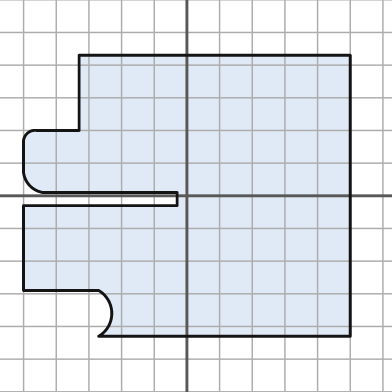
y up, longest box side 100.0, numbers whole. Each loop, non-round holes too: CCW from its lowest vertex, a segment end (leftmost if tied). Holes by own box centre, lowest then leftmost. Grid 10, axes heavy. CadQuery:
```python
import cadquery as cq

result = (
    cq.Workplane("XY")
    .moveTo(-27.0, -43.0)
    .lineTo(50.0, -43.0)
    .lineTo(50.0, 43.0)
    .lineTo(-33.0, 43.0)
    .lineTo(-33.0, 20.0)
    .lineTo(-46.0, 20.0)
    .threePointArc((-49.0, 19.0), (-50.0, 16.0))
    .lineTo(-50.0, 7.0)
    .threePointArc((-48.0, 3.0), (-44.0, 1.0))
    .lineTo(-3.0, 1.0)
    .lineTo(-3.0, -3.0)
    .lineTo(-50.0, -3.0)
    .lineTo(-50.0, -29.0)
    .lineTo(-27.0, -29.0)
    .threePointArc((-23.0, -36.0), (-27.0, -43.0))
    .close()
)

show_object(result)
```